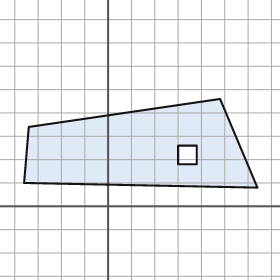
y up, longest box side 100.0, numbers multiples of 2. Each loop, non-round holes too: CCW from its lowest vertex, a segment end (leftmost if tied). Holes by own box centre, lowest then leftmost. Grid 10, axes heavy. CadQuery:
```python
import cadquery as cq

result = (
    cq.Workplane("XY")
    .moveTo(64.0, 8.0)
    .lineTo(48.0, 46.0)
    .lineTo(-34.0, 34.0)
    .lineTo(-36.0, 10.0)
    .close()
    .moveTo(30.0, 18.0)
    .lineTo(38.0, 18.0)
    .lineTo(38.0, 26.0)
    .lineTo(30.0, 26.0)
    .close()
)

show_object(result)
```